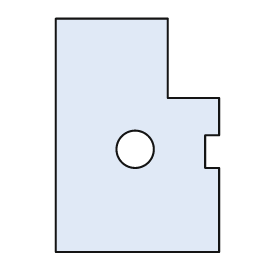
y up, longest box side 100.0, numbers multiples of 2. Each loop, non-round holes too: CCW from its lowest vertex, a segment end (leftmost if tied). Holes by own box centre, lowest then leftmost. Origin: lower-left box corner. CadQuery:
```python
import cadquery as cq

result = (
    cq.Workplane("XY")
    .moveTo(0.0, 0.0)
    .lineTo(70.0, 0.0)
    .lineTo(70.0, 36.0)
    .lineTo(64.0, 36.0)
    .lineTo(64.0, 50.0)
    .lineTo(70.0, 50.0)
    .lineTo(70.0, 66.0)
    .lineTo(48.0, 66.0)
    .lineTo(48.0, 100.0)
    .lineTo(0.0, 100.0)
    .close()
    .moveTo(34.0, 44.0)
    .circle(8.0)
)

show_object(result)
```